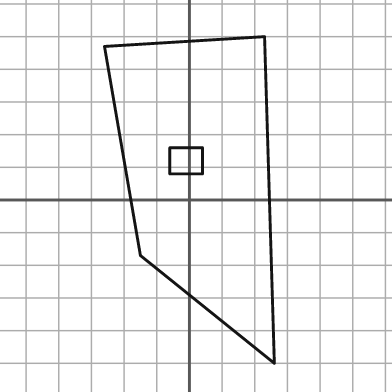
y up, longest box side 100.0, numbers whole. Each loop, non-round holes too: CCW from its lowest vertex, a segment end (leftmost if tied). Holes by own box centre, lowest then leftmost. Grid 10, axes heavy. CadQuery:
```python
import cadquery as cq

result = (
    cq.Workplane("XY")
    .moveTo(26.0, -50.0)
    .lineTo(23.0, 50.0)
    .lineTo(-26.0, 47.0)
    .lineTo(-15.0, -17.0)
    .close()
    .moveTo(-6.0, 8.0)
    .lineTo(4.0, 8.0)
    .lineTo(4.0, 16.0)
    .lineTo(-6.0, 16.0)
    .close()
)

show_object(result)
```